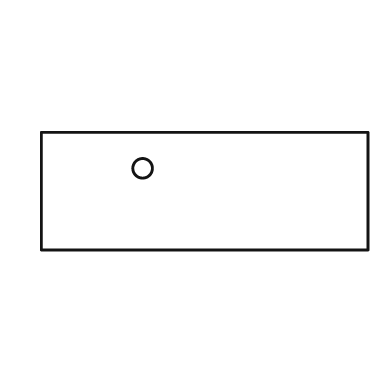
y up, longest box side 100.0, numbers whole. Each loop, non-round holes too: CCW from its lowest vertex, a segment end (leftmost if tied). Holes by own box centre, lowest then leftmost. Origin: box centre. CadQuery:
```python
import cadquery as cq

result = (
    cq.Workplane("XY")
    .moveTo(-50.0, -18.0)
    .lineTo(50.0, -18.0)
    .lineTo(50.0, 18.0)
    .lineTo(-50.0, 18.0)
    .close()
    .moveTo(-19.0, 7.0)
    .circle(3.0)
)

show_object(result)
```